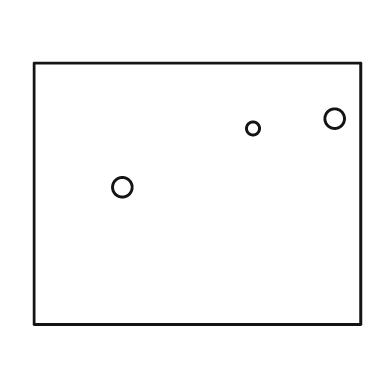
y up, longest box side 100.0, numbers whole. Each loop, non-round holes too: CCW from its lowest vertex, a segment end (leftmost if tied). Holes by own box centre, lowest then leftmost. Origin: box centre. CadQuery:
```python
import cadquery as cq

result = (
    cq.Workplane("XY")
    .moveTo(-50.0, -40.0)
    .lineTo(50.0, -40.0)
    .lineTo(50.0, 40.0)
    .lineTo(-50.0, 40.0)
    .close()
    .moveTo(-23.0, 2.0)
    .circle(3.0)
    .moveTo(17.0, 20.0)
    .circle(2.0)
    .moveTo(42.0, 23.0)
    .circle(3.0)
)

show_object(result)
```